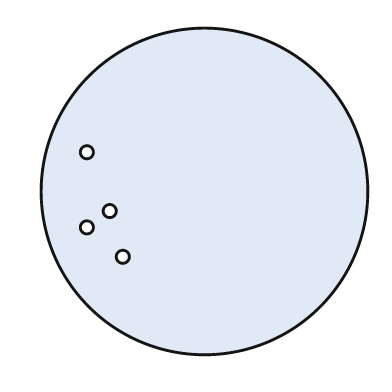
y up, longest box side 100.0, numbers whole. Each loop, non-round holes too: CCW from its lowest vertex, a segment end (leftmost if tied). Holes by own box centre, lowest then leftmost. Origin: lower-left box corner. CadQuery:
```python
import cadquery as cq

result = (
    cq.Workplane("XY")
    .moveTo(50.0, 50.0)
    .circle(50.0)
    .moveTo(25.0, 30.0)
    .circle(2.0)
    .moveTo(14.0, 39.0)
    .circle(2.0)
    .moveTo(21.0, 44.0)
    .circle(2.0)
    .moveTo(14.0, 62.0)
    .circle(2.0)
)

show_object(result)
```